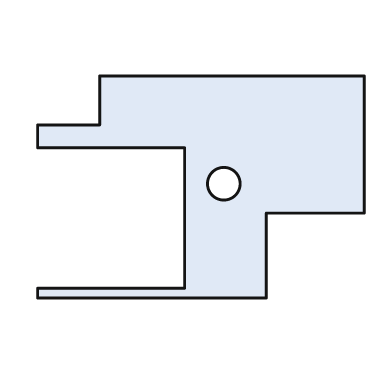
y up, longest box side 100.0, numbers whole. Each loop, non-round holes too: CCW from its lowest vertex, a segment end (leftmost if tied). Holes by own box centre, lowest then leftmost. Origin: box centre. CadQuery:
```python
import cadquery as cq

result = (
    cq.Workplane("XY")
    .moveTo(-50.0, -34.0)
    .lineTo(20.0, -34.0)
    .lineTo(20.0, -8.0)
    .lineTo(50.0, -8.0)
    .lineTo(50.0, 34.0)
    .lineTo(-31.0, 34.0)
    .lineTo(-31.0, 19.0)
    .lineTo(-50.0, 19.0)
    .lineTo(-50.0, 12.0)
    .lineTo(-5.0, 12.0)
    .lineTo(-5.0, -31.0)
    .lineTo(-50.0, -31.0)
    .close()
    .moveTo(7.0, 1.0)
    .circle(5.0)
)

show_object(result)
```